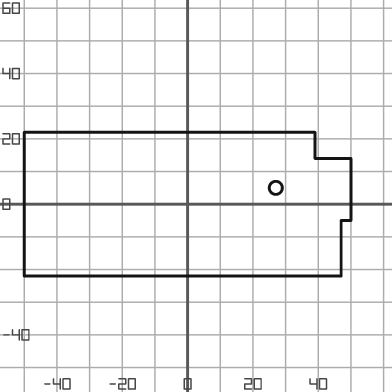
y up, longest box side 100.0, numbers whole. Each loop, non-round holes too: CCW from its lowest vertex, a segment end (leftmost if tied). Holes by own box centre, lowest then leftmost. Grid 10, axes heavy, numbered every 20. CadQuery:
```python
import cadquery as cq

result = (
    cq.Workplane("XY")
    .moveTo(-50.0, -22.0)
    .lineTo(47.0, -22.0)
    .lineTo(47.0, -5.0)
    .lineTo(50.0, -5.0)
    .lineTo(50.0, 14.0)
    .lineTo(39.0, 14.0)
    .lineTo(39.0, 22.0)
    .lineTo(-50.0, 22.0)
    .close()
    .moveTo(27.0, 5.0)
    .circle(2.0)
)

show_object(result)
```